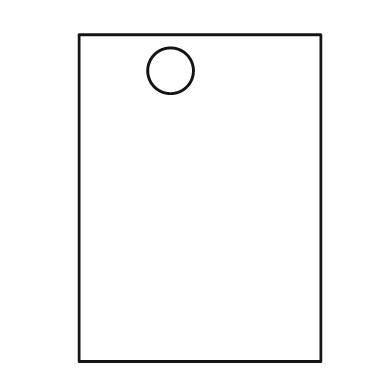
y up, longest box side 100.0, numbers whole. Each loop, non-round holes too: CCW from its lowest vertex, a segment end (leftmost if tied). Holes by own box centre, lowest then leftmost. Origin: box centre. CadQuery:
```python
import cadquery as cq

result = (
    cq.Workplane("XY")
    .moveTo(-37.0, -50.0)
    .lineTo(37.0, -50.0)
    .lineTo(37.0, 50.0)
    .lineTo(-37.0, 50.0)
    .close()
    .moveTo(-9.0, 39.0)
    .circle(7.0)
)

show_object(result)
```